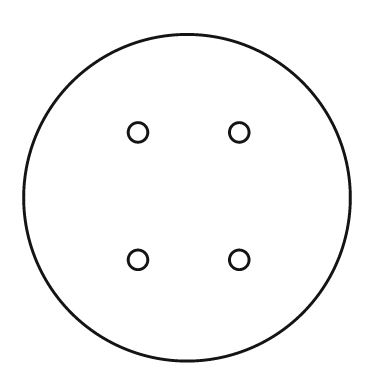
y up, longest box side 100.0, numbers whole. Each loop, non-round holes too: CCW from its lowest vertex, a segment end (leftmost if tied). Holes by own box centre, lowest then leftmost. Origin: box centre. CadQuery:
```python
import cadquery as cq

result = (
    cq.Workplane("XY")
    .moveTo(0.0, 0.0)
    .circle(50.0)
    .moveTo(-15.0, -19.0)
    .circle(3.0)
    .moveTo(16.0, -19.0)
    .circle(3.0)
    .moveTo(-15.0, 20.0)
    .circle(3.0)
    .moveTo(16.0, 20.0)
    .circle(3.0)
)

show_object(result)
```